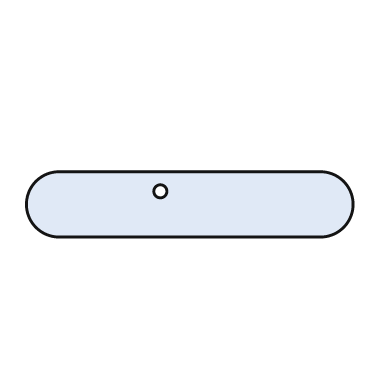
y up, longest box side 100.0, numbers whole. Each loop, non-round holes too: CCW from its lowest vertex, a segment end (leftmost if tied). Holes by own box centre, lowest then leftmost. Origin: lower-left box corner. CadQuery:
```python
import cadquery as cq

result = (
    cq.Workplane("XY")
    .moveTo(10.0, 0.0)
    .lineTo(90.0, 0.0)
    .threePointArc((100.0, 10.0), (90.0, 20.0))
    .lineTo(10.0, 20.0)
    .threePointArc((0.0, 10.0), (10.0, 0.0))
    .close()
    .moveTo(41.0, 14.0)
    .circle(2.0)
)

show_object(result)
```